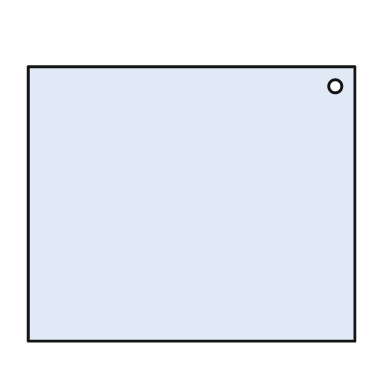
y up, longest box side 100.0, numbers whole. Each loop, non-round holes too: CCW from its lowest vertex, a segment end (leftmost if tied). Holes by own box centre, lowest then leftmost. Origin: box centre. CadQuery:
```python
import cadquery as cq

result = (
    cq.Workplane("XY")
    .moveTo(-50.0, -42.0)
    .lineTo(50.0, -42.0)
    .lineTo(50.0, 42.0)
    .lineTo(-50.0, 42.0)
    .close()
    .moveTo(44.0, 36.0)
    .circle(2.0)
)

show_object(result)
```